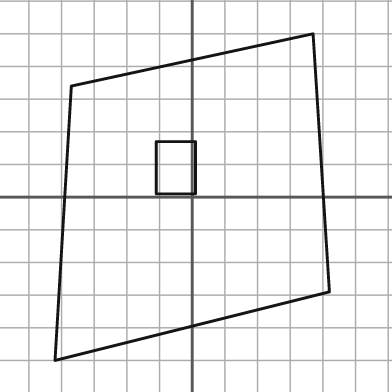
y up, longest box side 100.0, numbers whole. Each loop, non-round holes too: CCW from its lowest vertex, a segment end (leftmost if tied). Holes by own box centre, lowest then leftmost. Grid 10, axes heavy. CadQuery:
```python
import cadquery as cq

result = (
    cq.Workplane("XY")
    .moveTo(-42.0, -50.0)
    .lineTo(42.0, -29.0)
    .lineTo(37.0, 50.0)
    .lineTo(-37.0, 34.0)
    .close()
    .moveTo(-11.0, 1.0)
    .lineTo(1.0, 1.0)
    .lineTo(1.0, 17.0)
    .lineTo(-11.0, 17.0)
    .close()
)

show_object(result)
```